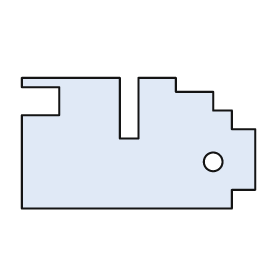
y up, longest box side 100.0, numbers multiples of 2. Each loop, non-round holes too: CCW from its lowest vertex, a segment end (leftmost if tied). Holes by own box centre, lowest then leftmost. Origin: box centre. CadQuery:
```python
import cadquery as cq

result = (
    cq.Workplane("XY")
    .moveTo(-50.0, -28.0)
    .lineTo(40.0, -28.0)
    .lineTo(40.0, -20.0)
    .lineTo(50.0, -20.0)
    .lineTo(50.0, 6.0)
    .lineTo(40.0, 6.0)
    .lineTo(40.0, 14.0)
    .lineTo(32.0, 14.0)
    .lineTo(32.0, 22.0)
    .lineTo(16.0, 22.0)
    .lineTo(16.0, 28.0)
    .lineTo(0.0, 28.0)
    .lineTo(0.0, 2.0)
    .lineTo(-8.0, 2.0)
    .lineTo(-8.0, 28.0)
    .lineTo(-50.0, 28.0)
    .lineTo(-50.0, 24.0)
    .lineTo(-34.0, 24.0)
    .lineTo(-34.0, 12.0)
    .lineTo(-50.0, 12.0)
    .close()
    .moveTo(32.0, -8.0)
    .circle(4.0)
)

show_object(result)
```